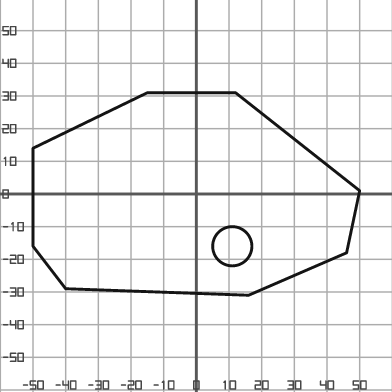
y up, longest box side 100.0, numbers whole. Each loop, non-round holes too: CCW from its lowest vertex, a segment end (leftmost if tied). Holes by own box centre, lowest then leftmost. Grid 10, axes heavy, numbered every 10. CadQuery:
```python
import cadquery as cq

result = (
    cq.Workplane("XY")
    .moveTo(16.0, -31.0)
    .lineTo(46.0, -18.0)
    .lineTo(50.0, 1.0)
    .lineTo(12.0, 31.0)
    .lineTo(-15.0, 31.0)
    .lineTo(-50.0, 14.0)
    .lineTo(-50.0, -16.0)
    .lineTo(-40.0, -29.0)
    .close()
    .moveTo(11.0, -16.0)
    .circle(6.0)
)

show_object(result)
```